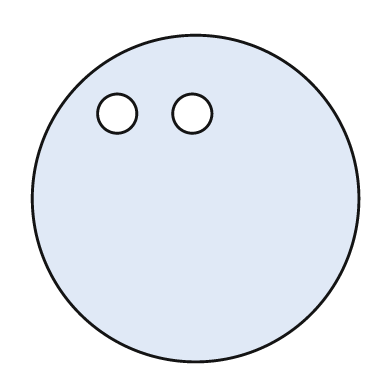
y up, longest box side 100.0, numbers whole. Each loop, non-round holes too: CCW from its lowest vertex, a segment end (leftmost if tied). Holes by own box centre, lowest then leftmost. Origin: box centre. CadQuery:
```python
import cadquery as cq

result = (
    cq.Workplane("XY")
    .moveTo(0.0, 0.0)
    .circle(50.0)
    .moveTo(-24.0, 26.0)
    .circle(6.0)
    .moveTo(-1.0, 26.0)
    .circle(6.0)
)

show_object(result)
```